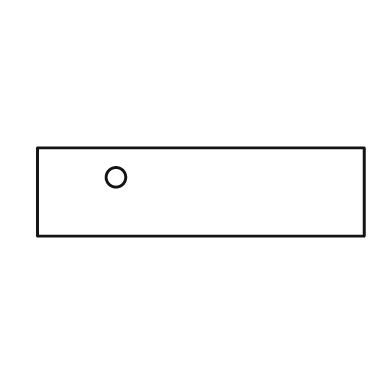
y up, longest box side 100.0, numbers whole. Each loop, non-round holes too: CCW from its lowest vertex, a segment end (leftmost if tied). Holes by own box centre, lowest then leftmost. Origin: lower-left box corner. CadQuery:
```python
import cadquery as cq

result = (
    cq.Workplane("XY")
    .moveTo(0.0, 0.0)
    .lineTo(100.0, 0.0)
    .lineTo(100.0, 27.0)
    .lineTo(0.0, 27.0)
    .close()
    .moveTo(24.0, 18.0)
    .circle(3.0)
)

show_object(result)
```